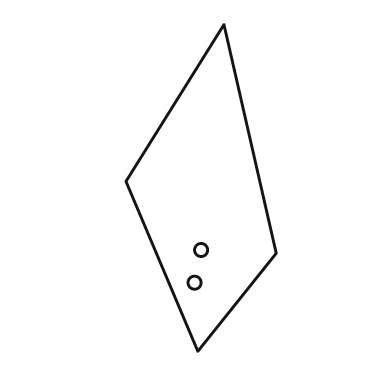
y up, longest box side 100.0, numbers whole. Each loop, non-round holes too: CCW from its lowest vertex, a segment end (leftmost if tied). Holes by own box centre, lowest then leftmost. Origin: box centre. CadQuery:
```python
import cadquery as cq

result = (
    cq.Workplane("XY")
    .moveTo(-1.0, -50.0)
    .lineTo(23.0, -20.0)
    .lineTo(7.0, 50.0)
    .lineTo(-23.0, 2.0)
    .close()
    .moveTo(-2.0, -29.0)
    .circle(2.0)
    .moveTo(0.0, -19.0)
    .circle(2.0)
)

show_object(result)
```